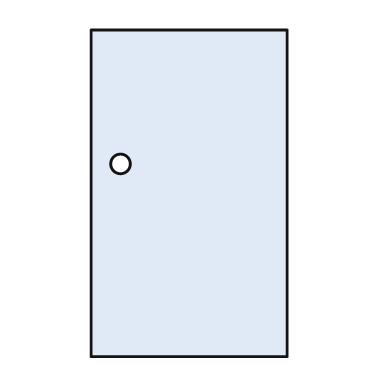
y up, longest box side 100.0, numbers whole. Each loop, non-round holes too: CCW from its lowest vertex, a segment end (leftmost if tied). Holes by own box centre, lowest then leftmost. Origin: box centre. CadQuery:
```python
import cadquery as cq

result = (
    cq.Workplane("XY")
    .moveTo(-30.0, -50.0)
    .lineTo(30.0, -50.0)
    .lineTo(30.0, 50.0)
    .lineTo(-30.0, 50.0)
    .close()
    .moveTo(-21.0, 9.0)
    .circle(3.0)
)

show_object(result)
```